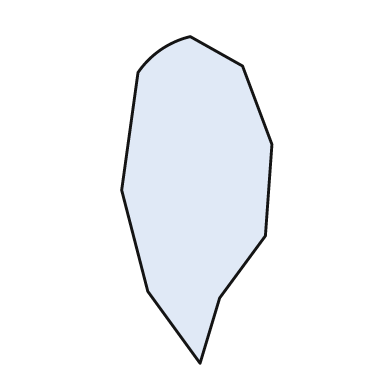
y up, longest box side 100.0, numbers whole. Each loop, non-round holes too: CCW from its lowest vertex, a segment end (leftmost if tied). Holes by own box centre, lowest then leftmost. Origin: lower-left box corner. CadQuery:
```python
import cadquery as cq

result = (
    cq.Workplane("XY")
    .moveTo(24.0, 0.0)
    .lineTo(30.0, 20.0)
    .lineTo(44.0, 39.0)
    .lineTo(46.0, 67.0)
    .lineTo(37.0, 91.0)
    .lineTo(21.0, 100.0)
    .threePointArc((12.0, 96.0), (5.0, 89.0))
    .lineTo(0.0, 53.0)
    .lineTo(8.0, 22.0)
    .close()
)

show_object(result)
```